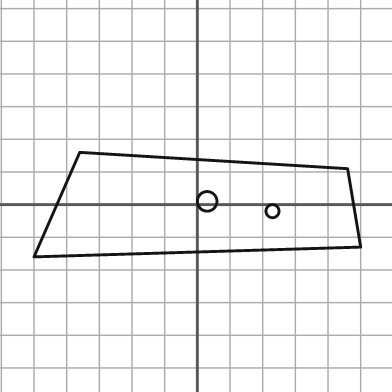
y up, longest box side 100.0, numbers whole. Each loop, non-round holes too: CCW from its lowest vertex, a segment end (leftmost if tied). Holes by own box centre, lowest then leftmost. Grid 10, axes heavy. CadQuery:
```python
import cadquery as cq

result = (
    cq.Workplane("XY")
    .moveTo(-50.0, -16.0)
    .lineTo(50.0, -13.0)
    .lineTo(46.0, 11.0)
    .lineTo(-36.0, 16.0)
    .close()
    .moveTo(23.0, -2.0)
    .circle(2.0)
    .moveTo(3.0, 1.0)
    .circle(3.0)
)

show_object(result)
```